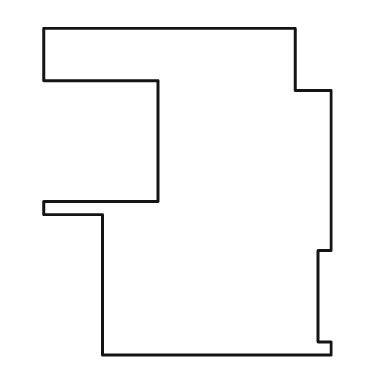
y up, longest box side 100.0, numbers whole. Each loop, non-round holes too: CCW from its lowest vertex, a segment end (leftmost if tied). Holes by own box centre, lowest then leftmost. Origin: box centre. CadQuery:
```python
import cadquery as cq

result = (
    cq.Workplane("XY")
    .moveTo(-26.0, -50.0)
    .lineTo(44.0, -50.0)
    .lineTo(44.0, -46.0)
    .lineTo(40.0, -46.0)
    .lineTo(40.0, -18.0)
    .lineTo(44.0, -18.0)
    .lineTo(44.0, 31.0)
    .lineTo(33.0, 31.0)
    .lineTo(33.0, 50.0)
    .lineTo(-44.0, 50.0)
    .lineTo(-44.0, 34.0)
    .lineTo(-9.0, 34.0)
    .lineTo(-9.0, -3.0)
    .lineTo(-44.0, -3.0)
    .lineTo(-44.0, -7.0)
    .lineTo(-26.0, -7.0)
    .close()
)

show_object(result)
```